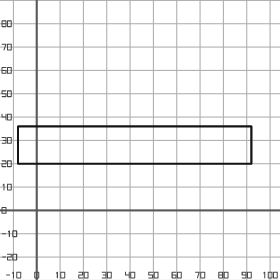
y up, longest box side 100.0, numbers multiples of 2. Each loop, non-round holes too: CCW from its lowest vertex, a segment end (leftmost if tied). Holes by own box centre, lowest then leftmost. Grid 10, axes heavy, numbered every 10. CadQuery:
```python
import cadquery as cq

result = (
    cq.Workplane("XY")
    .moveTo(-8.0, 20.0)
    .lineTo(92.0, 20.0)
    .lineTo(92.0, 36.0)
    .lineTo(-8.0, 36.0)
    .close()
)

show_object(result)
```